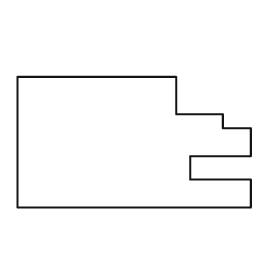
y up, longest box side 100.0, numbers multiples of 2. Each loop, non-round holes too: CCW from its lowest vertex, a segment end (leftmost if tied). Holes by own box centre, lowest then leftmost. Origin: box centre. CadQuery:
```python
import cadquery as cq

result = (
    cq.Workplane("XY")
    .moveTo(-50.0, -28.0)
    .lineTo(50.0, -28.0)
    .lineTo(50.0, -16.0)
    .lineTo(24.0, -16.0)
    .lineTo(24.0, -6.0)
    .lineTo(50.0, -6.0)
    .lineTo(50.0, 6.0)
    .lineTo(38.0, 6.0)
    .lineTo(38.0, 12.0)
    .lineTo(18.0, 12.0)
    .lineTo(18.0, 28.0)
    .lineTo(-50.0, 28.0)
    .close()
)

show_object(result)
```